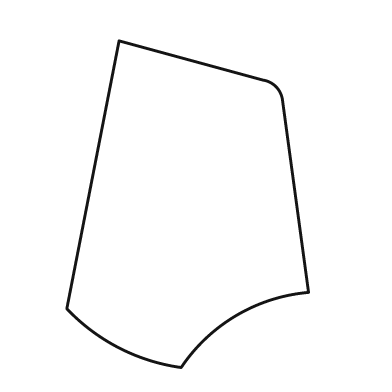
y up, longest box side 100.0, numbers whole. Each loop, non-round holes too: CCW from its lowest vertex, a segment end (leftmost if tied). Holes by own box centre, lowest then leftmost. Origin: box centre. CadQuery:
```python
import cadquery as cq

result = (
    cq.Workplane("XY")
    .moveTo(-2.0, -50.0)
    .threePointArc((15.0, -34.0), (37.0, -27.0))
    .lineTo(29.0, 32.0)
    .threePointArc((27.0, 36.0), (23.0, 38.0))
    .lineTo(-21.0, 50.0)
    .lineTo(-37.0, -32.0)
    .threePointArc((-21.0, -44.0), (-2.0, -50.0))
    .close()
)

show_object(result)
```